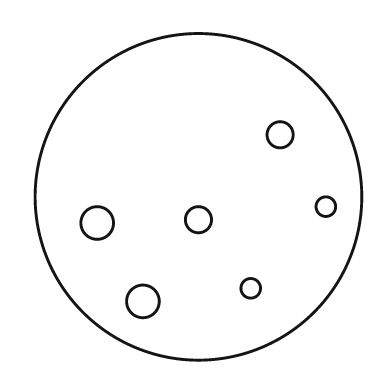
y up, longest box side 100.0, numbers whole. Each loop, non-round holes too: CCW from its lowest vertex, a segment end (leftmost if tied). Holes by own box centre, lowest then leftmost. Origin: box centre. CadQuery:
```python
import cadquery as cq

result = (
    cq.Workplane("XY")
    .moveTo(0.0, 0.0)
    .circle(50.0)
    .moveTo(-17.0, -32.0)
    .circle(5.0)
    .moveTo(16.0, -28.0)
    .circle(3.0)
    .moveTo(-31.0, -8.0)
    .circle(5.0)
    .moveTo(0.0, -7.0)
    .circle(4.0)
    .moveTo(39.0, -3.0)
    .circle(3.0)
    .moveTo(25.0, 19.0)
    .circle(4.0)
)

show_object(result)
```